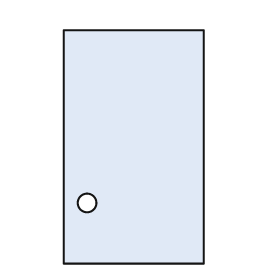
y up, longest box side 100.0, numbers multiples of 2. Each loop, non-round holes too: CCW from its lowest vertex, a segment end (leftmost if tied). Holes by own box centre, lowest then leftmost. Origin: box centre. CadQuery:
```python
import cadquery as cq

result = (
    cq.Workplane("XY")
    .moveTo(-30.0, -50.0)
    .lineTo(30.0, -50.0)
    .lineTo(30.0, 50.0)
    .lineTo(-30.0, 50.0)
    .close()
    .moveTo(-20.0, -24.0)
    .circle(4.0)
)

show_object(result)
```